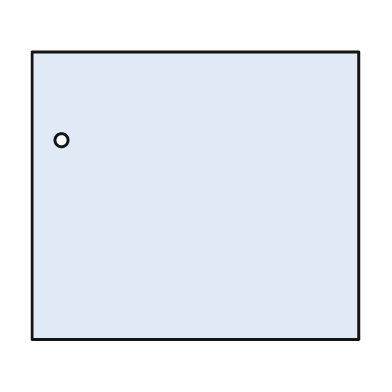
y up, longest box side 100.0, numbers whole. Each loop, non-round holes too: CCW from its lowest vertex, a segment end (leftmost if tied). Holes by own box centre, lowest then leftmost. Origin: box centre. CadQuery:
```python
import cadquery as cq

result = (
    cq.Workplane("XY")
    .moveTo(-50.0, -44.0)
    .lineTo(50.0, -44.0)
    .lineTo(50.0, 44.0)
    .lineTo(-50.0, 44.0)
    .close()
    .moveTo(-41.0, 17.0)
    .circle(2.0)
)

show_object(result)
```